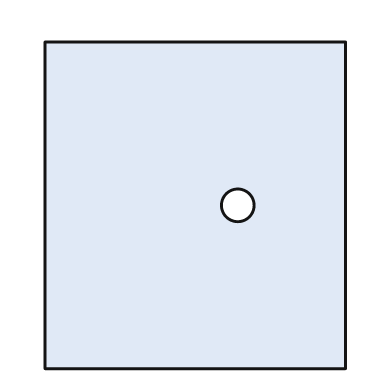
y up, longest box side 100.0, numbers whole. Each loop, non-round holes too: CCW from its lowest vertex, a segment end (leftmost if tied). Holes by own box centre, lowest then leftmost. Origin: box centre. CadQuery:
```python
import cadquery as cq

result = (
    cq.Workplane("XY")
    .moveTo(-46.0, -50.0)
    .lineTo(46.0, -50.0)
    .lineTo(46.0, 50.0)
    .lineTo(-46.0, 50.0)
    .close()
    .moveTo(13.0, 0.0)
    .circle(5.0)
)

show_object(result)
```